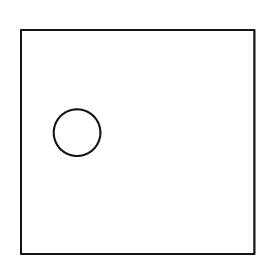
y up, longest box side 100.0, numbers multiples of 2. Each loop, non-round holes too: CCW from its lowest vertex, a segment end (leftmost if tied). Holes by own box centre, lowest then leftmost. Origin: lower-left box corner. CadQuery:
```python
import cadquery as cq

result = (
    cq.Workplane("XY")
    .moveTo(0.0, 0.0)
    .lineTo(100.0, 0.0)
    .lineTo(100.0, 96.0)
    .lineTo(0.0, 96.0)
    .close()
    .moveTo(24.0, 52.0)
    .circle(10.0)
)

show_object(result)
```